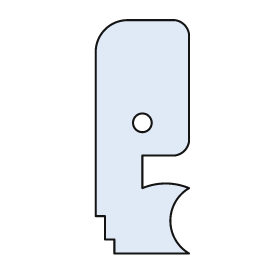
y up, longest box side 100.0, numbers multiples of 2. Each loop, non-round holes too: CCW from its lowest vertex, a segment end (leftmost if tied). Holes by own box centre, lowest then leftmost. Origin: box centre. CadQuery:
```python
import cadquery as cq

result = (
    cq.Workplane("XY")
    .moveTo(-12.0, -50.0)
    .lineTo(20.0, -50.0)
    .threePointArc((12.0, -36.0), (20.0, -22.0))
    .threePointArc((10.0, -20.0), (0.0, -22.0))
    .lineTo(0.0, -8.0)
    .lineTo(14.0, -8.0)
    .threePointArc((18.0, -6.0), (20.0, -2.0))
    .lineTo(20.0, 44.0)
    .threePointArc((18.0, 48.0), (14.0, 50.0))
    .lineTo(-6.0, 50.0)
    .threePointArc((-16.0, 46.0), (-20.0, 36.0))
    .lineTo(-20.0, -34.0)
    .lineTo(-16.0, -34.0)
    .lineTo(-16.0, -44.0)
    .lineTo(-12.0, -44.0)
    .close()
    .moveTo(0.0, 6.0)
    .circle(4.0)
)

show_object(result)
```